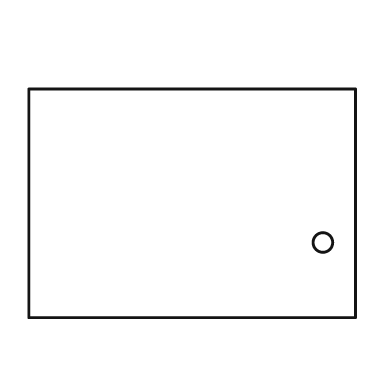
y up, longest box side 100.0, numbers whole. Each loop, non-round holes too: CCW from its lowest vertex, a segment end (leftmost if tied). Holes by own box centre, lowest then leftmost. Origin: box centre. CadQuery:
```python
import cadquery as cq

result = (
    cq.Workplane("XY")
    .moveTo(-50.0, -35.0)
    .lineTo(50.0, -35.0)
    .lineTo(50.0, 35.0)
    .lineTo(-50.0, 35.0)
    .close()
    .moveTo(40.0, -12.0)
    .circle(3.0)
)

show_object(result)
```